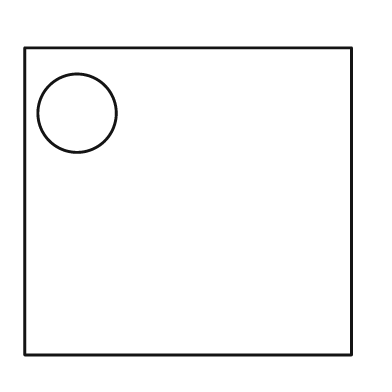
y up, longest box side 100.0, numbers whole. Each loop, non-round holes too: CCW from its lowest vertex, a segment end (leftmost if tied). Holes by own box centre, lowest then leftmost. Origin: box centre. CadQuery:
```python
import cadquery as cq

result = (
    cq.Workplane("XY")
    .moveTo(-50.0, -47.0)
    .lineTo(50.0, -47.0)
    .lineTo(50.0, 47.0)
    .lineTo(-50.0, 47.0)
    .close()
    .moveTo(-34.0, 27.0)
    .circle(12.0)
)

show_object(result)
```